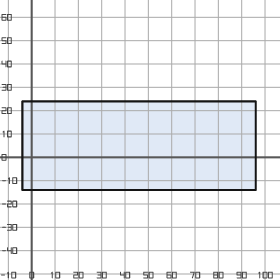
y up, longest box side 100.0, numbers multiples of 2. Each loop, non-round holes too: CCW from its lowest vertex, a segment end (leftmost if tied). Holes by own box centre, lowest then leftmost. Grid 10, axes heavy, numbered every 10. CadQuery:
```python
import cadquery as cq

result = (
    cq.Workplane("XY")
    .moveTo(-4.0, -14.0)
    .lineTo(96.0, -14.0)
    .lineTo(96.0, 24.0)
    .lineTo(-4.0, 24.0)
    .close()
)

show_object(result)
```